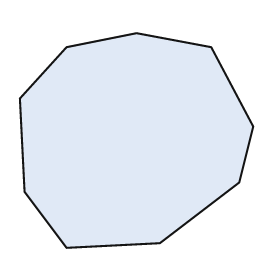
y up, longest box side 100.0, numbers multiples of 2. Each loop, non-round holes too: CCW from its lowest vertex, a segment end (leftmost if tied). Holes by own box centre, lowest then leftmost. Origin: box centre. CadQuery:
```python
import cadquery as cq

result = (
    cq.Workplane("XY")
    .moveTo(-30.0, -46.0)
    .lineTo(10.0, -44.0)
    .lineTo(44.0, -18.0)
    .lineTo(50.0, 6.0)
    .lineTo(32.0, 40.0)
    .lineTo(0.0, 46.0)
    .lineTo(-30.0, 40.0)
    .lineTo(-50.0, 18.0)
    .lineTo(-48.0, -22.0)
    .close()
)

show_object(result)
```